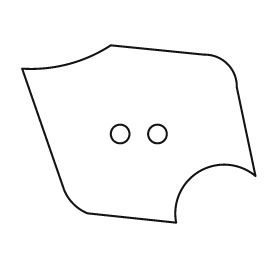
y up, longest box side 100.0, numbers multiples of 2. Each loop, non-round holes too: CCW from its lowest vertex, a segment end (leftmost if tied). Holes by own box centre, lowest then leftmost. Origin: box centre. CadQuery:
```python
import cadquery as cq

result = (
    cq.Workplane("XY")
    .moveTo(16.0, -38.0)
    .threePointArc((26.0, -16.0), (50.0, -18.0))
    .lineTo(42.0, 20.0)
    .threePointArc((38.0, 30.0), (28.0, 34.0))
    .lineTo(-12.0, 38.0)
    .threePointArc((-30.0, 30.0), (-50.0, 28.0))
    .lineTo(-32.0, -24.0)
    .threePointArc((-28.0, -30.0), (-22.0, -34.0))
    .close()
    .moveTo(-8.0, 0.0)
    .circle(4.0)
    .moveTo(8.0, 0.0)
    .circle(4.0)
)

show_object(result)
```